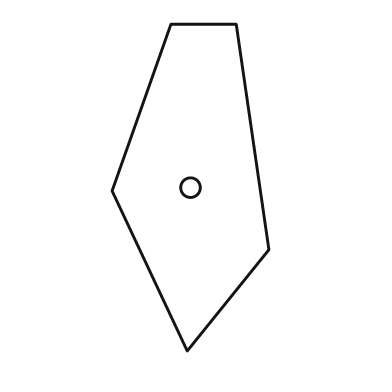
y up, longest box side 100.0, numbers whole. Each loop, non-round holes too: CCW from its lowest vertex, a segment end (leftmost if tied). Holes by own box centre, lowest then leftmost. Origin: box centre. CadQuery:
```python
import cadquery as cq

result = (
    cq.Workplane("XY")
    .moveTo(-1.0, -50.0)
    .lineTo(24.0, -19.0)
    .lineTo(14.0, 50.0)
    .lineTo(-6.0, 50.0)
    .lineTo(-24.0, -1.0)
    .close()
    .moveTo(0.0, 0.0)
    .circle(3.0)
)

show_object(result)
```